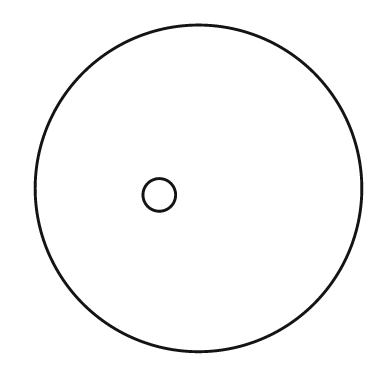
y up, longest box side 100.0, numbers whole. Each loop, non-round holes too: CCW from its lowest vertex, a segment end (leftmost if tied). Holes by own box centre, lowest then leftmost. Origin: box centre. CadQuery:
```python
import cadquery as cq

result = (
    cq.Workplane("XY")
    .moveTo(0.0, 0.0)
    .circle(50.0)
    .moveTo(-12.0, -2.0)
    .circle(5.0)
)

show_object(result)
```